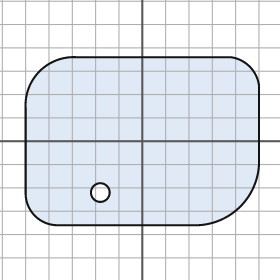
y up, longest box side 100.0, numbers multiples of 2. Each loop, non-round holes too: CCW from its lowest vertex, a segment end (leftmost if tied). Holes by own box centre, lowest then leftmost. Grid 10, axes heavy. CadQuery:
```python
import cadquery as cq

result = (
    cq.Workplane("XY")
    .moveTo(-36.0, -36.0)
    .lineTo(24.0, -36.0)
    .threePointArc((42.0, -28.0), (50.0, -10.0))
    .lineTo(50.0, 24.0)
    .threePointArc((46.0, 32.0), (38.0, 36.0))
    .lineTo(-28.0, 36.0)
    .threePointArc((-44.0, 30.0), (-50.0, 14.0))
    .lineTo(-50.0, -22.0)
    .threePointArc((-46.0, -32.0), (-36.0, -36.0))
    .close()
    .moveTo(-18.0, -22.0)
    .circle(4.0)
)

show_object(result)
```